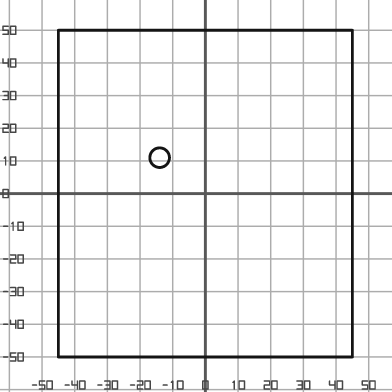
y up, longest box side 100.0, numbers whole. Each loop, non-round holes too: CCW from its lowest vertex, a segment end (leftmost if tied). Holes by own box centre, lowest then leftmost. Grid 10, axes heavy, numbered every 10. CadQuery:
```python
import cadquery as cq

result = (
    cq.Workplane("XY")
    .moveTo(-45.0, -50.0)
    .lineTo(45.0, -50.0)
    .lineTo(45.0, 50.0)
    .lineTo(-45.0, 50.0)
    .close()
    .moveTo(-14.0, 11.0)
    .circle(3.0)
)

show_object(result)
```